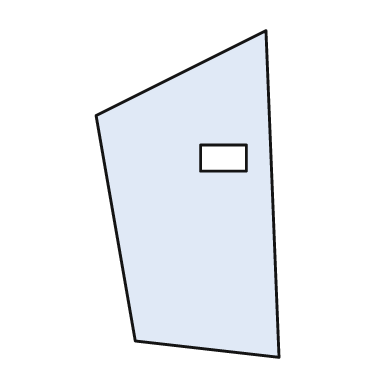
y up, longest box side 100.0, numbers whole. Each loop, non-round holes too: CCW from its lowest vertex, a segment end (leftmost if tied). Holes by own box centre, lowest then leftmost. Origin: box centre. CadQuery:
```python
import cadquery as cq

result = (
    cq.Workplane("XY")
    .moveTo(28.0, -50.0)
    .lineTo(24.0, 50.0)
    .lineTo(-28.0, 24.0)
    .lineTo(-16.0, -45.0)
    .close()
    .moveTo(4.0, 7.0)
    .lineTo(18.0, 7.0)
    .lineTo(18.0, 15.0)
    .lineTo(4.0, 15.0)
    .close()
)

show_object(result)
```